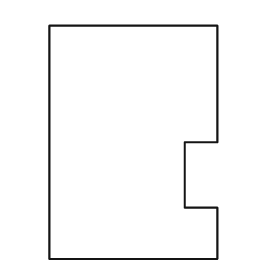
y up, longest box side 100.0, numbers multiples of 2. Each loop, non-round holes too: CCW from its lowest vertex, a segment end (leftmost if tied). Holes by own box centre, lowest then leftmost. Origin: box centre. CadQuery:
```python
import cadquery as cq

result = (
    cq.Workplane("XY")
    .moveTo(-36.0, -50.0)
    .lineTo(36.0, -50.0)
    .lineTo(36.0, -28.0)
    .lineTo(22.0, -28.0)
    .lineTo(22.0, 0.0)
    .lineTo(36.0, 0.0)
    .lineTo(36.0, 50.0)
    .lineTo(-36.0, 50.0)
    .close()
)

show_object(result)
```